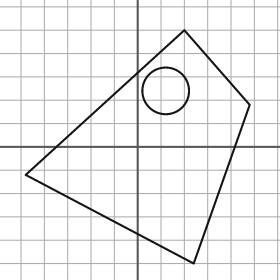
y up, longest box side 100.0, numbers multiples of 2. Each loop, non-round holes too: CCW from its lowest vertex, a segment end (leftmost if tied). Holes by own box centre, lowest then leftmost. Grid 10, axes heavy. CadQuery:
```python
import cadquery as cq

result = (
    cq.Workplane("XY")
    .moveTo(24.0, -50.0)
    .lineTo(48.0, 18.0)
    .lineTo(20.0, 50.0)
    .lineTo(-48.0, -12.0)
    .close()
    .moveTo(12.0, 24.0)
    .circle(10.0)
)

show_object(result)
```